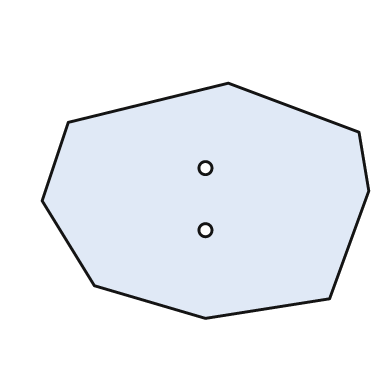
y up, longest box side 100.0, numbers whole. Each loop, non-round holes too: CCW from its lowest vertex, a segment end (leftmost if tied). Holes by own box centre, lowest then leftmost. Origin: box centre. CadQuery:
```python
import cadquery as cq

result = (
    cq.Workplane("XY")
    .moveTo(0.0, -36.0)
    .lineTo(38.0, -30.0)
    .lineTo(50.0, 3.0)
    .lineTo(47.0, 21.0)
    .lineTo(7.0, 36.0)
    .lineTo(-42.0, 24.0)
    .lineTo(-50.0, 0.0)
    .lineTo(-34.0, -26.0)
    .close()
    .moveTo(0.0, -9.0)
    .circle(2.0)
    .moveTo(0.0, 10.0)
    .circle(2.0)
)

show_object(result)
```